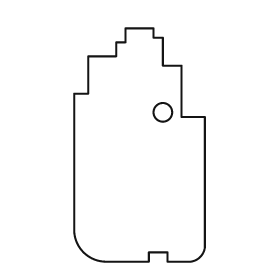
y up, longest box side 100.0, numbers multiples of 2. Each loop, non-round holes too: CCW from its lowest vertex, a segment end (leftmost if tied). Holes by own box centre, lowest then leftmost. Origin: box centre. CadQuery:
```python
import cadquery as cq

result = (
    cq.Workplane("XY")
    .moveTo(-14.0, -50.0)
    .lineTo(4.0, -50.0)
    .lineTo(4.0, -46.0)
    .lineTo(12.0, -46.0)
    .lineTo(12.0, -50.0)
    .lineTo(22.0, -50.0)
    .threePointArc((26.0, -48.0), (28.0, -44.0))
    .lineTo(28.0, 12.0)
    .lineTo(18.0, 12.0)
    .lineTo(18.0, 34.0)
    .lineTo(10.0, 34.0)
    .lineTo(10.0, 46.0)
    .lineTo(6.0, 46.0)
    .lineTo(6.0, 50.0)
    .lineTo(-6.0, 50.0)
    .lineTo(-6.0, 44.0)
    .lineTo(-10.0, 44.0)
    .lineTo(-10.0, 38.0)
    .lineTo(-22.0, 38.0)
    .lineTo(-22.0, 22.0)
    .lineTo(-28.0, 22.0)
    .lineTo(-28.0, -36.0)
    .threePointArc((-24.0, -46.0), (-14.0, -50.0))
    .close()
    .moveTo(10.0, 14.0)
    .circle(4.0)
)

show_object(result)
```